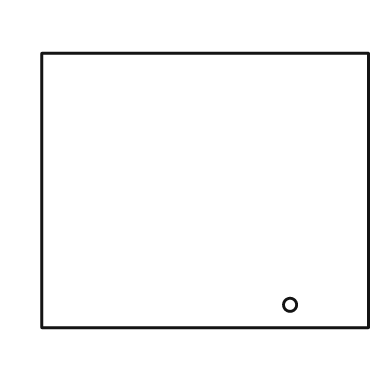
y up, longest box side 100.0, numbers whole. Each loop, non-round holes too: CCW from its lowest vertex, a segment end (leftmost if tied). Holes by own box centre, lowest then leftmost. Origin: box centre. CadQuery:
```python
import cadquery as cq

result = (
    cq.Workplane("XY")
    .moveTo(-50.0, -42.0)
    .lineTo(50.0, -42.0)
    .lineTo(50.0, 42.0)
    .lineTo(-50.0, 42.0)
    .close()
    .moveTo(26.0, -35.0)
    .circle(2.0)
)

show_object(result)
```